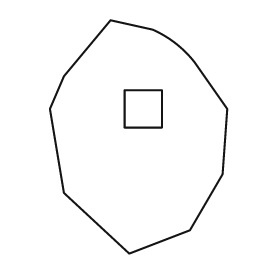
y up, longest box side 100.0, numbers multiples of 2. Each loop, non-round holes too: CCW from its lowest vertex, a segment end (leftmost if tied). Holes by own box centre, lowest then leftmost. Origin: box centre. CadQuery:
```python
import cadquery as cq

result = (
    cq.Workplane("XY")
    .moveTo(-4.0, -50.0)
    .lineTo(22.0, -40.0)
    .lineTo(36.0, -16.0)
    .lineTo(38.0, 12.0)
    .lineTo(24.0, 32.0)
    .threePointArc((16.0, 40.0), (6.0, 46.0))
    .lineTo(-12.0, 50.0)
    .lineTo(-32.0, 26.0)
    .lineTo(-38.0, 12.0)
    .lineTo(-32.0, -24.0)
    .close()
    .moveTo(-6.0, 4.0)
    .lineTo(10.0, 4.0)
    .lineTo(10.0, 20.0)
    .lineTo(-6.0, 20.0)
    .close()
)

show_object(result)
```